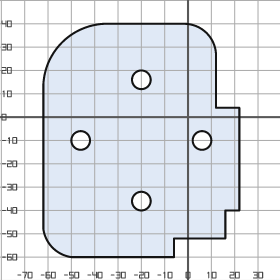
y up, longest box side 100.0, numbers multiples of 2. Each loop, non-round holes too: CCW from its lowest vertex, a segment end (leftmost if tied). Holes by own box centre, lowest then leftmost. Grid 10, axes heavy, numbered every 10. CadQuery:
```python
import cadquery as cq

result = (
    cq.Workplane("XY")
    .moveTo(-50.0, -60.0)
    .lineTo(-6.0, -60.0)
    .lineTo(-6.0, -52.0)
    .lineTo(16.0, -52.0)
    .lineTo(16.0, -40.0)
    .lineTo(22.0, -40.0)
    .lineTo(22.0, 4.0)
    .lineTo(12.0, 4.0)
    .lineTo(12.0, 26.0)
    .threePointArc((8.0, 36.0), (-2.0, 40.0))
    .lineTo(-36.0, 40.0)
    .threePointArc((-54.0, 32.0), (-62.0, 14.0))
    .lineTo(-62.0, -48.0)
    .threePointArc((-58.0, -56.0), (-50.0, -60.0))
    .close()
    .moveTo(-20.0, -36.0)
    .circle(4.0)
    .moveTo(-46.0, -10.0)
    .circle(4.0)
    .moveTo(6.0, -10.0)
    .circle(4.0)
    .moveTo(-20.0, 16.0)
    .circle(4.0)
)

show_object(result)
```